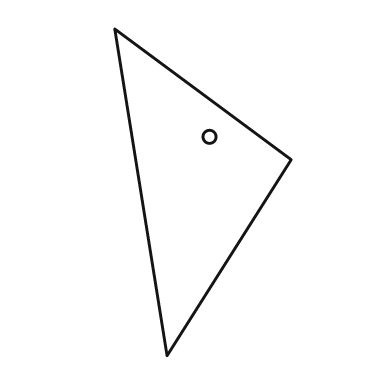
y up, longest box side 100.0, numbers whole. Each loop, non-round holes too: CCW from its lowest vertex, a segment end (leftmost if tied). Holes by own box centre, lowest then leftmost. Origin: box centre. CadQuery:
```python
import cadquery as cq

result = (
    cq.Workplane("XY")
    .moveTo(-11.0, -50.0)
    .lineTo(27.0, 10.0)
    .lineTo(-27.0, 50.0)
    .close()
    .moveTo(2.0, 17.0)
    .circle(2.0)
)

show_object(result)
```